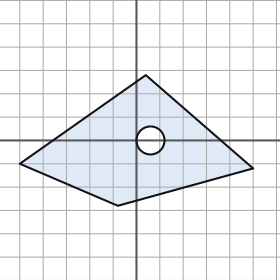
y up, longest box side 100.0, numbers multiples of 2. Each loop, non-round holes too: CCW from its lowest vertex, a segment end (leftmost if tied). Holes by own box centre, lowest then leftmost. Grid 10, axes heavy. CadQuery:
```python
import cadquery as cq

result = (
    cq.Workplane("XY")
    .moveTo(-8.0, -28.0)
    .lineTo(50.0, -12.0)
    .lineTo(4.0, 28.0)
    .lineTo(-50.0, -10.0)
    .close()
    .moveTo(6.0, 0.0)
    .circle(6.0)
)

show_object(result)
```